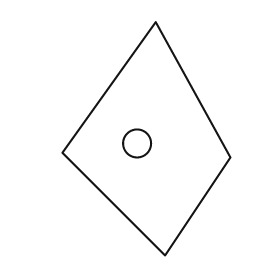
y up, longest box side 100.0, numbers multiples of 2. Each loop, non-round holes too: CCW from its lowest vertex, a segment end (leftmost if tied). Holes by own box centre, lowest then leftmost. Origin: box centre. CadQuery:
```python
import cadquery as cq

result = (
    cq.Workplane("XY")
    .moveTo(8.0, -50.0)
    .lineTo(36.0, -8.0)
    .lineTo(4.0, 50.0)
    .lineTo(-36.0, -6.0)
    .close()
    .moveTo(-4.0, -2.0)
    .circle(6.0)
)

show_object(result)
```